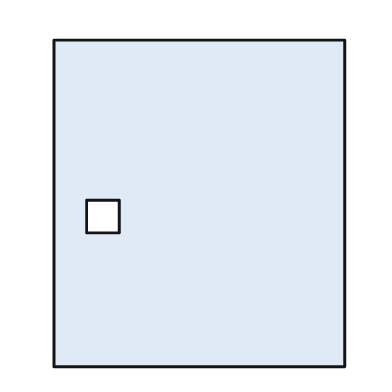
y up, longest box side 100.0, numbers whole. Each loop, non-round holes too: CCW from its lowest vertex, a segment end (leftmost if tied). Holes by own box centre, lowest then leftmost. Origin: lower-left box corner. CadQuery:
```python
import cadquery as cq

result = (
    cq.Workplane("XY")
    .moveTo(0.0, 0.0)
    .lineTo(89.0, 0.0)
    .lineTo(89.0, 100.0)
    .lineTo(0.0, 100.0)
    .close()
    .moveTo(10.0, 41.0)
    .lineTo(20.0, 41.0)
    .lineTo(20.0, 51.0)
    .lineTo(10.0, 51.0)
    .close()
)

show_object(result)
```